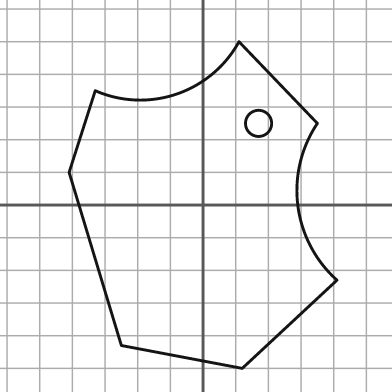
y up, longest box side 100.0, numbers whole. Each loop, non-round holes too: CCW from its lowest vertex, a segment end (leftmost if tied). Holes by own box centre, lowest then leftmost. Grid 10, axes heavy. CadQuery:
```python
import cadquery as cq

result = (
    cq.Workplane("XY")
    .moveTo(12.0, -50.0)
    .lineTo(41.0, -23.0)
    .threePointArc((29.0, 0.0), (35.0, 25.0))
    .lineTo(11.0, 50.0)
    .threePointArc((-8.0, 34.0), (-33.0, 35.0))
    .lineTo(-41.0, 10.0)
    .lineTo(-25.0, -43.0)
    .close()
    .moveTo(17.0, 25.0)
    .circle(4.0)
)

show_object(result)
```